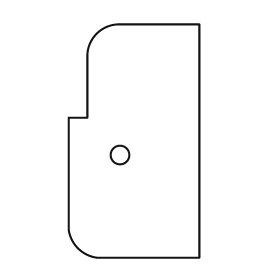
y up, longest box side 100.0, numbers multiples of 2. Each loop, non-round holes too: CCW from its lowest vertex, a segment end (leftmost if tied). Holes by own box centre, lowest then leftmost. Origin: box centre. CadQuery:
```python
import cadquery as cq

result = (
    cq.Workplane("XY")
    .moveTo(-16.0, -50.0)
    .lineTo(28.0, -50.0)
    .lineTo(28.0, 50.0)
    .lineTo(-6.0, 50.0)
    .threePointArc((-16.0, 46.0), (-20.0, 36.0))
    .lineTo(-20.0, 10.0)
    .lineTo(-28.0, 10.0)
    .lineTo(-28.0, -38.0)
    .threePointArc((-24.0, -46.0), (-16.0, -50.0))
    .close()
    .moveTo(-6.0, -6.0)
    .circle(4.0)
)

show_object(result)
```